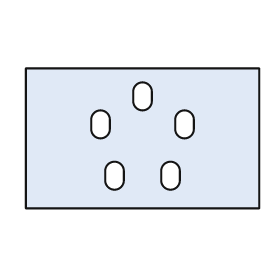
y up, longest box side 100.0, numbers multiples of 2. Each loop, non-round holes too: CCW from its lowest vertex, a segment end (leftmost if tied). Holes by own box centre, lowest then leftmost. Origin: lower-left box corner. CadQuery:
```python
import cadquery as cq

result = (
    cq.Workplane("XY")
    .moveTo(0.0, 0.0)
    .lineTo(100.0, 0.0)
    .lineTo(100.0, 60.0)
    .lineTo(0.0, 60.0)
    .close()
    .moveTo(34.0, 12.0)
    .threePointArc((38.0, 8.0), (42.0, 12.0))
    .lineTo(42.0, 16.0)
    .threePointArc((38.0, 20.0), (34.0, 16.0))
    .close()
    .moveTo(58.0, 12.0)
    .threePointArc((62.0, 8.0), (66.0, 12.0))
    .lineTo(66.0, 16.0)
    .threePointArc((62.0, 20.0), (58.0, 16.0))
    .close()
    .moveTo(28.0, 34.0)
    .threePointArc((32.0, 30.0), (36.0, 34.0))
    .lineTo(36.0, 38.0)
    .threePointArc((32.0, 42.0), (28.0, 38.0))
    .close()
    .moveTo(64.0, 34.0)
    .threePointArc((68.0, 30.0), (72.0, 34.0))
    .lineTo(72.0, 38.0)
    .threePointArc((68.0, 42.0), (64.0, 38.0))
    .close()
    .moveTo(46.0, 46.0)
    .threePointArc((50.0, 42.0), (54.0, 46.0))
    .lineTo(54.0, 50.0)
    .threePointArc((50.0, 54.0), (46.0, 50.0))
    .close()
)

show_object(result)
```